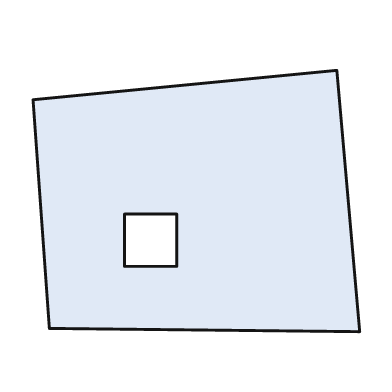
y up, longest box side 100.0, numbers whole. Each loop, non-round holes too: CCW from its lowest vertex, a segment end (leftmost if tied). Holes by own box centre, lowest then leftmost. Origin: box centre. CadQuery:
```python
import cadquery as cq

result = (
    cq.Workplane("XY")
    .moveTo(50.0, -40.0)
    .lineTo(43.0, 40.0)
    .lineTo(-50.0, 31.0)
    .lineTo(-45.0, -39.0)
    .close()
    .moveTo(-22.0, -20.0)
    .lineTo(-6.0, -20.0)
    .lineTo(-6.0, -4.0)
    .lineTo(-22.0, -4.0)
    .close()
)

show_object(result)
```